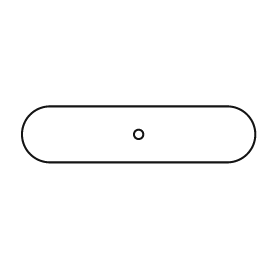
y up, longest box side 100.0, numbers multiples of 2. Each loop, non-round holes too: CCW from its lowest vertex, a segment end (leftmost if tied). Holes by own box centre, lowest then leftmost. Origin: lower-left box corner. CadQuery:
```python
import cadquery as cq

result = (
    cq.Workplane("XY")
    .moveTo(12.0, 0.0)
    .lineTo(88.0, 0.0)
    .threePointArc((100.0, 12.0), (88.0, 24.0))
    .lineTo(12.0, 24.0)
    .threePointArc((0.0, 12.0), (12.0, 0.0))
    .close()
    .moveTo(50.0, 12.0)
    .circle(2.0)
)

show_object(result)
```